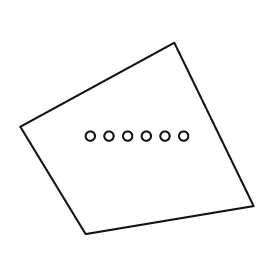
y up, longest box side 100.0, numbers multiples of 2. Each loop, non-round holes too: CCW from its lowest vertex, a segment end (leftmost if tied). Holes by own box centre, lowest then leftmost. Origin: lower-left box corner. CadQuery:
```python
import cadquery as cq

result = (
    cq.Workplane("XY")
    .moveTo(28.0, 0.0)
    .lineTo(100.0, 12.0)
    .lineTo(66.0, 82.0)
    .lineTo(0.0, 46.0)
    .close()
    .moveTo(30.0, 42.0)
    .circle(2.0)
    .moveTo(38.0, 42.0)
    .circle(2.0)
    .moveTo(46.0, 42.0)
    .circle(2.0)
    .moveTo(54.0, 42.0)
    .circle(2.0)
    .moveTo(62.0, 42.0)
    .circle(2.0)
    .moveTo(70.0, 42.0)
    .circle(2.0)
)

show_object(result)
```